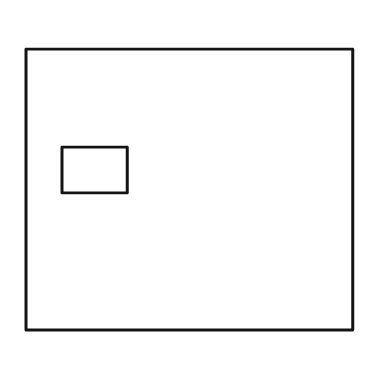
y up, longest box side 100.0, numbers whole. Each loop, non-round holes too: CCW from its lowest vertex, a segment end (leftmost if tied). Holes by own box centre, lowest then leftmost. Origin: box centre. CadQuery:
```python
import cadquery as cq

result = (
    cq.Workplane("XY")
    .moveTo(-50.0, -43.0)
    .lineTo(50.0, -43.0)
    .lineTo(50.0, 43.0)
    .lineTo(-50.0, 43.0)
    .close()
    .moveTo(-39.0, -1.0)
    .lineTo(-19.0, -1.0)
    .lineTo(-19.0, 13.0)
    .lineTo(-39.0, 13.0)
    .close()
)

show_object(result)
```